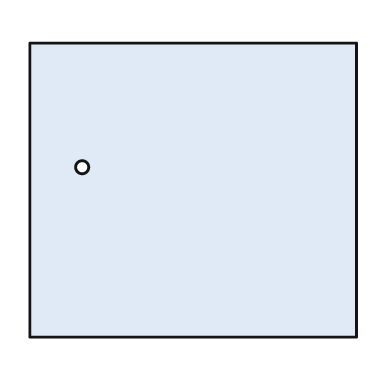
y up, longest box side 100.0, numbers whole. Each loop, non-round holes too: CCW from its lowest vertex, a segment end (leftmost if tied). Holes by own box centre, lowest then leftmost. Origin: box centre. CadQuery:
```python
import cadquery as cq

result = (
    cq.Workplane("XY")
    .moveTo(-50.0, -45.0)
    .lineTo(50.0, -45.0)
    .lineTo(50.0, 45.0)
    .lineTo(-50.0, 45.0)
    .close()
    .moveTo(-34.0, 7.0)
    .circle(2.0)
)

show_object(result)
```